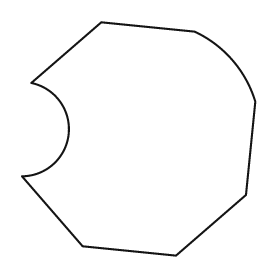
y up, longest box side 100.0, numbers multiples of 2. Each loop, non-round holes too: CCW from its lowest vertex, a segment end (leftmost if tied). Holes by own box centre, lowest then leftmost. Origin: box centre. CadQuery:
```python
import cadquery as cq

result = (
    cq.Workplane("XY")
    .moveTo(16.0, -50.0)
    .lineTo(46.0, -24.0)
    .lineTo(50.0, 16.0)
    .threePointArc((40.0, 34.0), (24.0, 46.0))
    .lineTo(-16.0, 50.0)
    .lineTo(-46.0, 24.0)
    .threePointArc((-30.0, 2.0), (-50.0, -16.0))
    .lineTo(-24.0, -46.0)
    .close()
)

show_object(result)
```